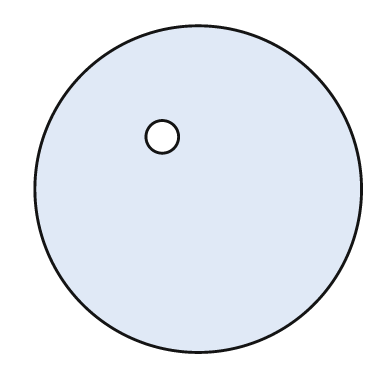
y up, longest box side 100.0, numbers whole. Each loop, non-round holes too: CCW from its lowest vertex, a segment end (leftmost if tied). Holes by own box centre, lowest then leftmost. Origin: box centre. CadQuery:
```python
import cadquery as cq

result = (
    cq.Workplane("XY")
    .moveTo(0.0, 0.0)
    .circle(50.0)
    .moveTo(-11.0, 16.0)
    .circle(5.0)
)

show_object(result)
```